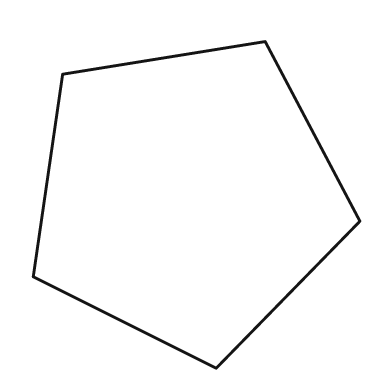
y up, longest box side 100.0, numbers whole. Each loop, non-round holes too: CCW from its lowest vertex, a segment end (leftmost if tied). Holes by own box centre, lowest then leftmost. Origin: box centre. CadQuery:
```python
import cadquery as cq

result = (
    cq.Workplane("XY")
    .moveTo(6.0, -50.0)
    .lineTo(50.0, -5.0)
    .lineTo(21.0, 50.0)
    .lineTo(-41.0, 40.0)
    .lineTo(-50.0, -22.0)
    .close()
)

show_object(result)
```